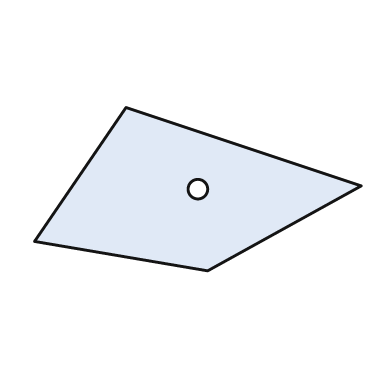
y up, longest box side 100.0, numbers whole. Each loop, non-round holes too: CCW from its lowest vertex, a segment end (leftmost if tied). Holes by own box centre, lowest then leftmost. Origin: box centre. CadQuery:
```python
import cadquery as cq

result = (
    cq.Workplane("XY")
    .moveTo(3.0, -25.0)
    .lineTo(50.0, 1.0)
    .lineTo(-22.0, 25.0)
    .lineTo(-50.0, -16.0)
    .close()
    .moveTo(0.0, 0.0)
    .circle(3.0)
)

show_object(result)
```